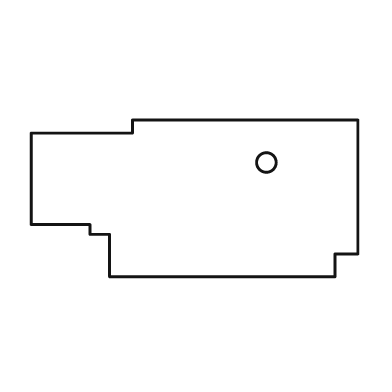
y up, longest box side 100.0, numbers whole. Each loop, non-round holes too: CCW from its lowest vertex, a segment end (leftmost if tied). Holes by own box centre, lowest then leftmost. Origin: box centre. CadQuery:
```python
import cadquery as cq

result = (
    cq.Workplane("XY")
    .moveTo(-26.0, -24.0)
    .lineTo(43.0, -24.0)
    .lineTo(43.0, -17.0)
    .lineTo(50.0, -17.0)
    .lineTo(50.0, 24.0)
    .lineTo(-19.0, 24.0)
    .lineTo(-19.0, 20.0)
    .lineTo(-50.0, 20.0)
    .lineTo(-50.0, -8.0)
    .lineTo(-32.0, -8.0)
    .lineTo(-32.0, -11.0)
    .lineTo(-26.0, -11.0)
    .close()
    .moveTo(22.0, 11.0)
    .circle(3.0)
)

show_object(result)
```